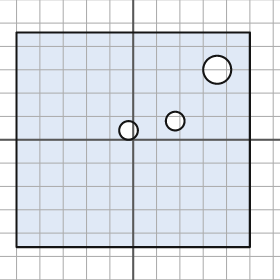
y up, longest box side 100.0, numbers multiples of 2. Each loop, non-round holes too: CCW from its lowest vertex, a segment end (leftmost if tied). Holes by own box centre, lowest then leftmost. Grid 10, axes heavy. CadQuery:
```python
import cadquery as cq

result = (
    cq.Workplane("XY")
    .moveTo(-50.0, -46.0)
    .lineTo(50.0, -46.0)
    .lineTo(50.0, 46.0)
    .lineTo(-50.0, 46.0)
    .close()
    .moveTo(-2.0, 4.0)
    .circle(4.0)
    .moveTo(18.0, 8.0)
    .circle(4.0)
    .moveTo(36.0, 30.0)
    .circle(6.0)
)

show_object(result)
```